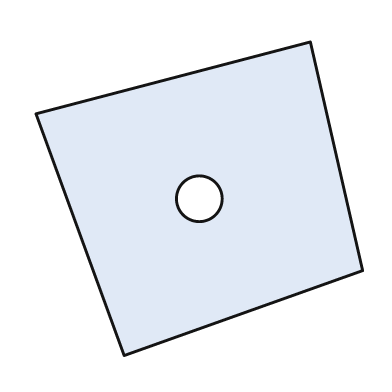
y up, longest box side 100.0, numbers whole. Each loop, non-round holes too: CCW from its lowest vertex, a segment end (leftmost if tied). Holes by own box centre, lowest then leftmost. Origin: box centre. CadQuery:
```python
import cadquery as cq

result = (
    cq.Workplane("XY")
    .moveTo(-23.0, -48.0)
    .lineTo(50.0, -22.0)
    .lineTo(34.0, 48.0)
    .lineTo(-50.0, 26.0)
    .close()
    .moveTo(0.0, 0.0)
    .circle(7.0)
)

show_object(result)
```